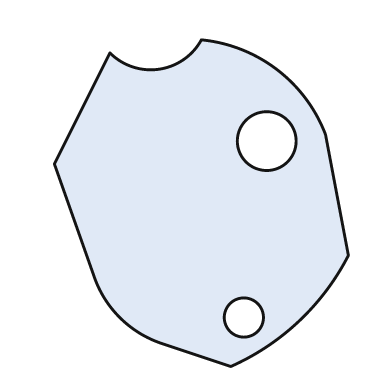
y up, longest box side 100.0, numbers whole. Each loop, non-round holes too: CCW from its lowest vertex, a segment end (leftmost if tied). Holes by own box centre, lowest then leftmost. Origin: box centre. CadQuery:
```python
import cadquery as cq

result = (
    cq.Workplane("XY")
    .moveTo(9.0, -50.0)
    .threePointArc((30.0, -36.0), (45.0, -16.0))
    .lineTo(38.0, 21.0)
    .threePointArc((23.0, 41.0), (0.0, 50.0))
    .threePointArc((-13.0, 41.0), (-28.0, 46.0))
    .lineTo(-45.0, 12.0)
    .lineTo(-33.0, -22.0)
    .threePointArc((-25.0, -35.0), (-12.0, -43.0))
    .close()
    .moveTo(13.0, -35.0)
    .circle(6.0)
    .moveTo(20.0, 19.0)
    .circle(9.0)
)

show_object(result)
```